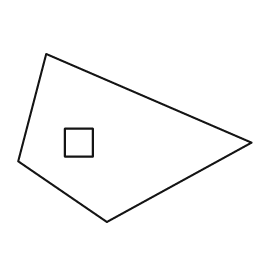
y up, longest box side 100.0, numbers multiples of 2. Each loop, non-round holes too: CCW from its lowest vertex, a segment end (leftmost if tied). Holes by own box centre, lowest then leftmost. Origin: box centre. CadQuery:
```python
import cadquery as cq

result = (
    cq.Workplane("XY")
    .moveTo(-12.0, -36.0)
    .lineTo(50.0, -2.0)
    .lineTo(-38.0, 36.0)
    .lineTo(-50.0, -10.0)
    .close()
    .moveTo(-30.0, -8.0)
    .lineTo(-18.0, -8.0)
    .lineTo(-18.0, 4.0)
    .lineTo(-30.0, 4.0)
    .close()
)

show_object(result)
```